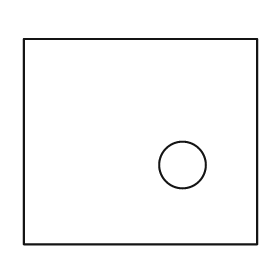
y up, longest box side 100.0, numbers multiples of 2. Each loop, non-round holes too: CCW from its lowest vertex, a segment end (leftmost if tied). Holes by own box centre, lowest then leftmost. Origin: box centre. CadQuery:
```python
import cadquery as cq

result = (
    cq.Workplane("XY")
    .moveTo(-50.0, -44.0)
    .lineTo(50.0, -44.0)
    .lineTo(50.0, 44.0)
    .lineTo(-50.0, 44.0)
    .close()
    .moveTo(18.0, -10.0)
    .circle(10.0)
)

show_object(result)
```